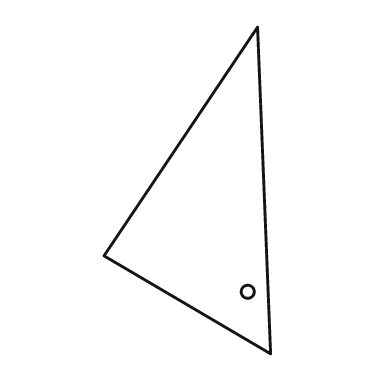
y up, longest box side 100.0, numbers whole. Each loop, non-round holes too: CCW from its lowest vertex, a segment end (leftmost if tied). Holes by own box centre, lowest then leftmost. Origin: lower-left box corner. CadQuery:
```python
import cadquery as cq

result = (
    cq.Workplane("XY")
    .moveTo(51.0, 0.0)
    .lineTo(47.0, 100.0)
    .lineTo(0.0, 30.0)
    .close()
    .moveTo(44.0, 19.0)
    .circle(2.0)
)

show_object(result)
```